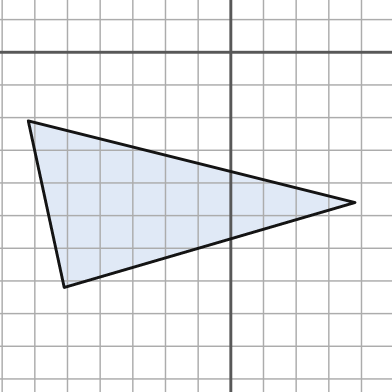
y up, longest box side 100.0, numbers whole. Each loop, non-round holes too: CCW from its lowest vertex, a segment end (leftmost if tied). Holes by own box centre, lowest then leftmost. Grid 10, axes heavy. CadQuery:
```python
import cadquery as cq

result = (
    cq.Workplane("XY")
    .moveTo(-51.0, -72.0)
    .lineTo(38.0, -46.0)
    .lineTo(-62.0, -21.0)
    .close()
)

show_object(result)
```